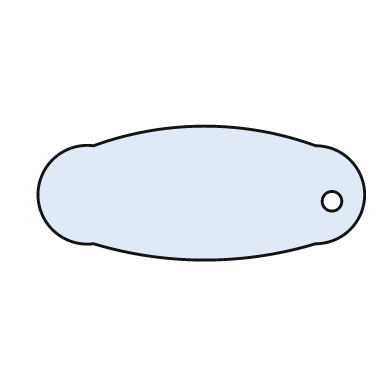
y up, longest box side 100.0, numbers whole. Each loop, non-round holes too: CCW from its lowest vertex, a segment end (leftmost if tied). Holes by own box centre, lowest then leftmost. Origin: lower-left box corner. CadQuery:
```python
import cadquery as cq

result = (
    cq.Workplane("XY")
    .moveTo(17.0, 5.0)
    .threePointArc((51.0, 0.0), (85.0, 5.0))
    .threePointArc((100.0, 20.0), (85.0, 35.0))
    .threePointArc((51.0, 41.0), (17.0, 35.0))
    .threePointArc((0.0, 20.0), (17.0, 5.0))
    .close()
    .moveTo(90.0, 18.0)
    .circle(3.0)
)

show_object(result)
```